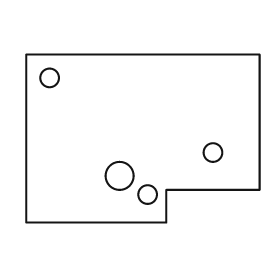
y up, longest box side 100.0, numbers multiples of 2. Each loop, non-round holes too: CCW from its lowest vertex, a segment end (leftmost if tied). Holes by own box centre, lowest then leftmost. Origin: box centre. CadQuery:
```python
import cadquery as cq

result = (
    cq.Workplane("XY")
    .moveTo(-50.0, -36.0)
    .lineTo(10.0, -36.0)
    .lineTo(10.0, -22.0)
    .lineTo(50.0, -22.0)
    .lineTo(50.0, 36.0)
    .lineTo(-50.0, 36.0)
    .close()
    .moveTo(2.0, -24.0)
    .circle(4.0)
    .moveTo(-10.0, -16.0)
    .circle(6.0)
    .moveTo(30.0, -6.0)
    .circle(4.0)
    .moveTo(-40.0, 26.0)
    .circle(4.0)
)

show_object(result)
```